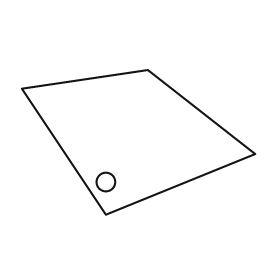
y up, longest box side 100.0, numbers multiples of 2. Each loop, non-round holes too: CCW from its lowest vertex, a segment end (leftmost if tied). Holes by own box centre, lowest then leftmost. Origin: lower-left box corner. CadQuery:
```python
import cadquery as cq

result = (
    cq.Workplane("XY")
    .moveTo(36.0, 0.0)
    .lineTo(100.0, 26.0)
    .lineTo(54.0, 62.0)
    .lineTo(0.0, 54.0)
    .close()
    .moveTo(36.0, 14.0)
    .circle(4.0)
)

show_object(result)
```